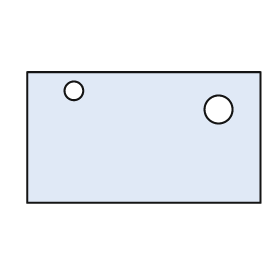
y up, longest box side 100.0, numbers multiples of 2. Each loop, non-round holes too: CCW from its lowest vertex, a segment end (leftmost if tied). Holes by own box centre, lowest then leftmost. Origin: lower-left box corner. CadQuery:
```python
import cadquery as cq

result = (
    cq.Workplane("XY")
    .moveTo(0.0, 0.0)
    .lineTo(100.0, 0.0)
    .lineTo(100.0, 56.0)
    .lineTo(0.0, 56.0)
    .close()
    .moveTo(82.0, 40.0)
    .circle(6.0)
    .moveTo(20.0, 48.0)
    .circle(4.0)
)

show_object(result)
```